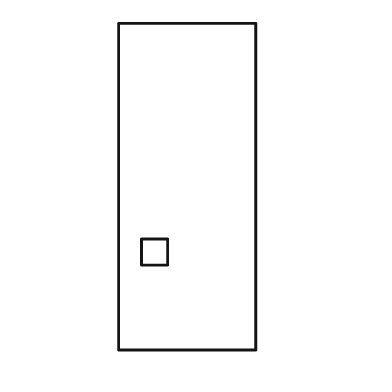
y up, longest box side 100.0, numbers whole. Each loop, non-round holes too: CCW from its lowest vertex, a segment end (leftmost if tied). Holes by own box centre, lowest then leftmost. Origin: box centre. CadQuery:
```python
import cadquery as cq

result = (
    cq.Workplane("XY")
    .moveTo(-21.0, -50.0)
    .lineTo(21.0, -50.0)
    .lineTo(21.0, 50.0)
    .lineTo(-21.0, 50.0)
    .close()
    .moveTo(-14.0, -24.0)
    .lineTo(-6.0, -24.0)
    .lineTo(-6.0, -16.0)
    .lineTo(-14.0, -16.0)
    .close()
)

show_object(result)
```